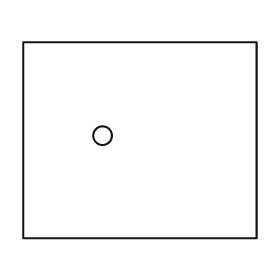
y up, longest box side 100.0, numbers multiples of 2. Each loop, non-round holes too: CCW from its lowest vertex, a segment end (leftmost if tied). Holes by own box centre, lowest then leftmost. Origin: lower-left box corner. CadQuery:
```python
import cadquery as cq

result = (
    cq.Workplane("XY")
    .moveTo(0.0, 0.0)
    .lineTo(100.0, 0.0)
    .lineTo(100.0, 84.0)
    .lineTo(0.0, 84.0)
    .close()
    .moveTo(34.0, 44.0)
    .circle(4.0)
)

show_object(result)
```